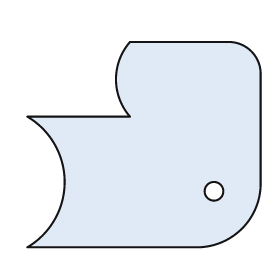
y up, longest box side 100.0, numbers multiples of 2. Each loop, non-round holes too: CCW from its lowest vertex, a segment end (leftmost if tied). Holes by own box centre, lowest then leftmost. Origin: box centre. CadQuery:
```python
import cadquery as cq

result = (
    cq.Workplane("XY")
    .moveTo(-50.0, -44.0)
    .lineTo(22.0, -44.0)
    .threePointArc((42.0, -36.0), (50.0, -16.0))
    .lineTo(50.0, 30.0)
    .threePointArc((46.0, 40.0), (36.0, 44.0))
    .lineTo(-6.0, 44.0)
    .threePointArc((-12.0, 28.0), (-6.0, 12.0))
    .lineTo(-50.0, 12.0)
    .threePointArc((-34.0, -16.0), (-50.0, -44.0))
    .close()
    .moveTo(30.0, -20.0)
    .circle(4.0)
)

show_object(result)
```